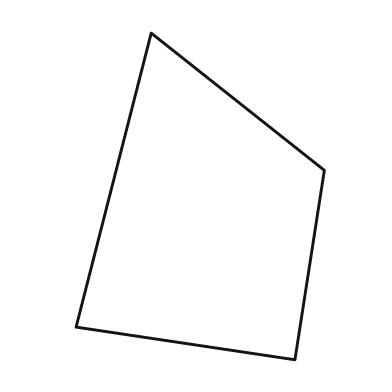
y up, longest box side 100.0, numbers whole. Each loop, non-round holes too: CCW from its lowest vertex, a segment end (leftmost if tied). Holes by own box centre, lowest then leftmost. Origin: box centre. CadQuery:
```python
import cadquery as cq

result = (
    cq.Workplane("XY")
    .moveTo(29.0, -50.0)
    .lineTo(38.0, 8.0)
    .lineTo(-15.0, 50.0)
    .lineTo(-38.0, -40.0)
    .close()
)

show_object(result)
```